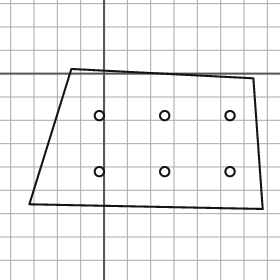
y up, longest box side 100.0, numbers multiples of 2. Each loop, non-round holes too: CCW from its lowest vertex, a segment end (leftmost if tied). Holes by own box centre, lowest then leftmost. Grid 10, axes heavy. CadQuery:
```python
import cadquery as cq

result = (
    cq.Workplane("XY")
    .moveTo(68.0, -58.0)
    .lineTo(64.0, -2.0)
    .lineTo(-14.0, 2.0)
    .lineTo(-32.0, -56.0)
    .close()
    .moveTo(-2.0, -42.0)
    .circle(2.0)
    .moveTo(26.0, -42.0)
    .circle(2.0)
    .moveTo(54.0, -42.0)
    .circle(2.0)
    .moveTo(-2.0, -18.0)
    .circle(2.0)
    .moveTo(26.0, -18.0)
    .circle(2.0)
    .moveTo(54.0, -18.0)
    .circle(2.0)
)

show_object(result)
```